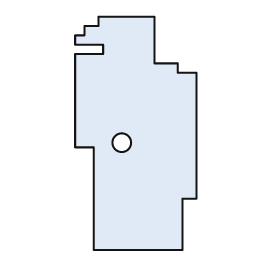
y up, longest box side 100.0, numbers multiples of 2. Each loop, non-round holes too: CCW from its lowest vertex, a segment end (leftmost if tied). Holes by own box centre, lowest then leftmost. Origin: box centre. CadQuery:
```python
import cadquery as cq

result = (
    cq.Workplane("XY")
    .moveTo(-18.0, -50.0)
    .lineTo(20.0, -50.0)
    .lineTo(20.0, -28.0)
    .lineTo(26.0, -28.0)
    .lineTo(26.0, 26.0)
    .lineTo(18.0, 26.0)
    .lineTo(18.0, 30.0)
    .lineTo(8.0, 30.0)
    .lineTo(8.0, 50.0)
    .lineTo(-16.0, 50.0)
    .lineTo(-16.0, 46.0)
    .lineTo(-22.0, 46.0)
    .lineTo(-22.0, 42.0)
    .lineTo(-26.0, 42.0)
    .lineTo(-26.0, 38.0)
    .lineTo(-14.0, 38.0)
    .lineTo(-14.0, 34.0)
    .lineTo(-26.0, 34.0)
    .lineTo(-26.0, -6.0)
    .lineTo(-18.0, -6.0)
    .close()
    .moveTo(-6.0, -4.0)
    .circle(4.0)
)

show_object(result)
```